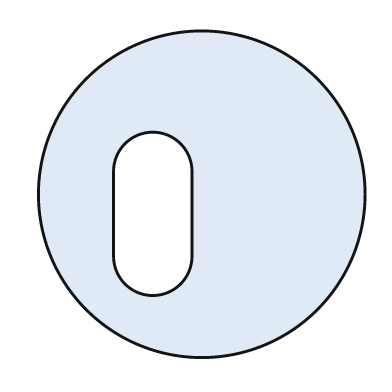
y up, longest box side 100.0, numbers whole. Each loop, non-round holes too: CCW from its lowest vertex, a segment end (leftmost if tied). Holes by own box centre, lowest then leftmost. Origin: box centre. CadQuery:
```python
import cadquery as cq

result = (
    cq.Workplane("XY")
    .moveTo(0.0, 0.0)
    .circle(50.0)
    .moveTo(-27.0, -19.0)
    .threePointArc((-15.0, -31.0), (-3.0, -19.0))
    .lineTo(-3.0, 7.0)
    .threePointArc((-15.0, 19.0), (-27.0, 7.0))
    .close()
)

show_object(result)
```